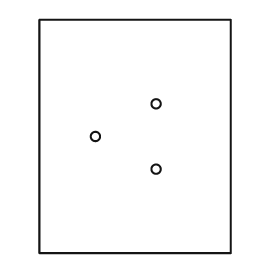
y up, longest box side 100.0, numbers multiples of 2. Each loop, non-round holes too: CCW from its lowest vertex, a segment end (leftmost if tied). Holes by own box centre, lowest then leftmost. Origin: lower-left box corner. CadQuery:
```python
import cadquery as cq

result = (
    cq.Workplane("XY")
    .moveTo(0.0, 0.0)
    .lineTo(82.0, 0.0)
    .lineTo(82.0, 100.0)
    .lineTo(0.0, 100.0)
    .close()
    .moveTo(50.0, 36.0)
    .circle(2.0)
    .moveTo(24.0, 50.0)
    .circle(2.0)
    .moveTo(50.0, 64.0)
    .circle(2.0)
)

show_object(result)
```